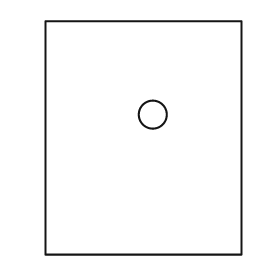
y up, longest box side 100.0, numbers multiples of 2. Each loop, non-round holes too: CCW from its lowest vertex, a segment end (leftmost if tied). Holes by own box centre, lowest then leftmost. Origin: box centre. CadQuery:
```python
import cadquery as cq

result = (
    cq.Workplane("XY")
    .moveTo(-42.0, -50.0)
    .lineTo(42.0, -50.0)
    .lineTo(42.0, 50.0)
    .lineTo(-42.0, 50.0)
    .close()
    .moveTo(4.0, 10.0)
    .circle(6.0)
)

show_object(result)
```